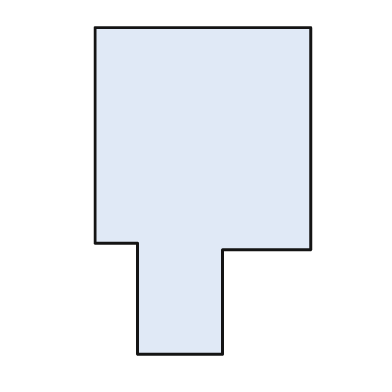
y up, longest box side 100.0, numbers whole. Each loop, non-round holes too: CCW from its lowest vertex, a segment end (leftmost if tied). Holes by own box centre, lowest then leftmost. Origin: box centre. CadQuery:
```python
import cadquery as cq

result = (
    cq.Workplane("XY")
    .moveTo(-20.0, -50.0)
    .lineTo(6.0, -50.0)
    .lineTo(6.0, -18.0)
    .lineTo(33.0, -18.0)
    .lineTo(33.0, 50.0)
    .lineTo(-33.0, 50.0)
    .lineTo(-33.0, -16.0)
    .lineTo(-20.0, -16.0)
    .close()
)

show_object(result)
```